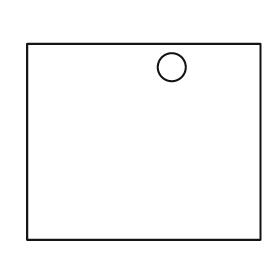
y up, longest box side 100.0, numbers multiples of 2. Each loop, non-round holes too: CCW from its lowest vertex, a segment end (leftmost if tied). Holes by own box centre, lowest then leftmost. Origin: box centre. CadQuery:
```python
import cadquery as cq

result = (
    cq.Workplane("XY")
    .moveTo(-50.0, -42.0)
    .lineTo(50.0, -42.0)
    .lineTo(50.0, 42.0)
    .lineTo(-50.0, 42.0)
    .close()
    .moveTo(12.0, 32.0)
    .circle(6.0)
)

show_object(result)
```